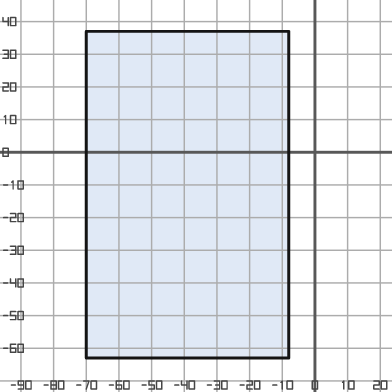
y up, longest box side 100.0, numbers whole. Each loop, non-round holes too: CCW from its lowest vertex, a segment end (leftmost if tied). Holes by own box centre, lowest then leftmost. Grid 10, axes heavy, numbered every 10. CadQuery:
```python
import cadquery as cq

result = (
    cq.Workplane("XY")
    .moveTo(-70.0, -63.0)
    .lineTo(-8.0, -63.0)
    .lineTo(-8.0, 37.0)
    .lineTo(-70.0, 37.0)
    .close()
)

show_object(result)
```